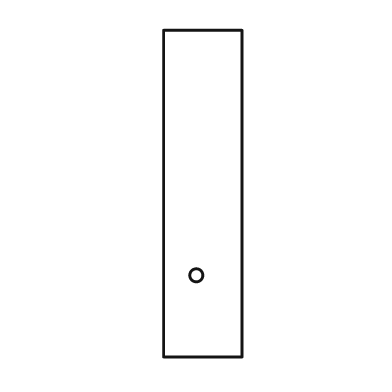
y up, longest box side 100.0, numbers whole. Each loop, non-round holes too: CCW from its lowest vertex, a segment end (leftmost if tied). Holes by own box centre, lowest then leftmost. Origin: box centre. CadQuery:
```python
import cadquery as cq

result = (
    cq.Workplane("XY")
    .moveTo(-12.0, -50.0)
    .lineTo(12.0, -50.0)
    .lineTo(12.0, 50.0)
    .lineTo(-12.0, 50.0)
    .close()
    .moveTo(-2.0, -25.0)
    .circle(2.0)
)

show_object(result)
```